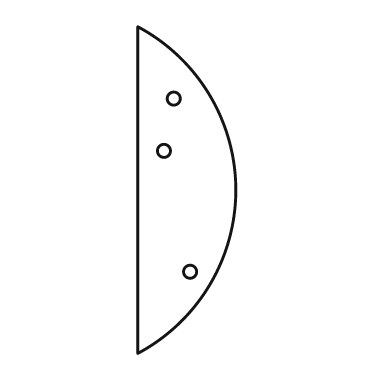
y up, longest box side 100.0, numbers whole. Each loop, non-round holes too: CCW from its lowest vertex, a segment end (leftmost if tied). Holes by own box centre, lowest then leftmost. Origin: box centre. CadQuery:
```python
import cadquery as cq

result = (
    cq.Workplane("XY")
    .moveTo(-15.0, -50.0)
    .threePointArc((15.0, 0.0), (-15.0, 50.0))
    .close()
    .moveTo(1.0, -25.0)
    .circle(2.0)
    .moveTo(-7.0, 12.0)
    .circle(2.0)
    .moveTo(-4.0, 28.0)
    .circle(2.0)
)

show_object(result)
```